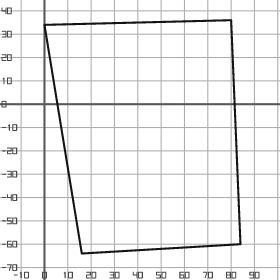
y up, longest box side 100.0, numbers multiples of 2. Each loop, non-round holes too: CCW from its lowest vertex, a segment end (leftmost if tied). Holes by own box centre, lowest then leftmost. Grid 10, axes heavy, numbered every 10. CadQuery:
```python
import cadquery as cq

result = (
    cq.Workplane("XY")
    .moveTo(16.0, -64.0)
    .lineTo(84.0, -60.0)
    .lineTo(80.0, 36.0)
    .lineTo(0.0, 34.0)
    .close()
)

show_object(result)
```